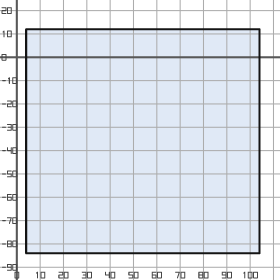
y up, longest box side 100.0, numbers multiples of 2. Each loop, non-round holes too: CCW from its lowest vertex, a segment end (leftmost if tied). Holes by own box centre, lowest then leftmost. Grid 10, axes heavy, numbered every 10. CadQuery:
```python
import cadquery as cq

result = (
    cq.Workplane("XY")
    .moveTo(4.0, -84.0)
    .lineTo(104.0, -84.0)
    .lineTo(104.0, 12.0)
    .lineTo(4.0, 12.0)
    .close()
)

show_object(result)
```